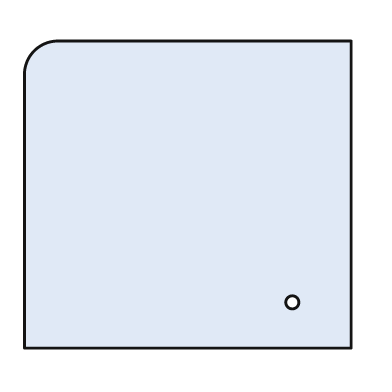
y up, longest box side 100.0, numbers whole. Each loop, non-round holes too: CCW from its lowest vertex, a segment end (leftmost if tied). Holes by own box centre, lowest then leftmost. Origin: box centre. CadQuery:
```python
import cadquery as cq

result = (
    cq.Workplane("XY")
    .moveTo(-50.0, -47.0)
    .lineTo(50.0, -47.0)
    .lineTo(50.0, 47.0)
    .lineTo(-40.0, 47.0)
    .threePointArc((-47.0, 44.0), (-50.0, 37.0))
    .close()
    .moveTo(32.0, -33.0)
    .circle(2.0)
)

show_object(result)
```